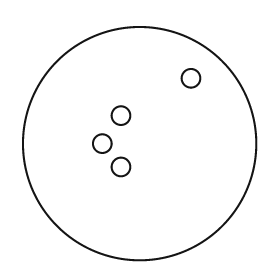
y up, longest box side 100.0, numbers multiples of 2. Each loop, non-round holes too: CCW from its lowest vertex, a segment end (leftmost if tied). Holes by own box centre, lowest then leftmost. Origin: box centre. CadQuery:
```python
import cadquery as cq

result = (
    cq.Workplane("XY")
    .moveTo(0.0, 0.0)
    .circle(50.0)
    .moveTo(-8.0, -10.0)
    .circle(4.0)
    .moveTo(-16.0, 0.0)
    .circle(4.0)
    .moveTo(-8.0, 12.0)
    .circle(4.0)
    .moveTo(22.0, 28.0)
    .circle(4.0)
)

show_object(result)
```